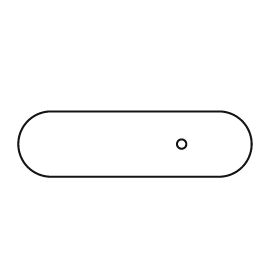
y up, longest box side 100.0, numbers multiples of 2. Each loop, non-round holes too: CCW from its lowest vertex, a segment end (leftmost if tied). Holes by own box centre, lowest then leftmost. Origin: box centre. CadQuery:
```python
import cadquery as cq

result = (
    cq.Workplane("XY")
    .moveTo(-36.0, -14.0)
    .lineTo(36.0, -14.0)
    .threePointArc((50.0, 0.0), (36.0, 14.0))
    .lineTo(-36.0, 14.0)
    .threePointArc((-50.0, 0.0), (-36.0, -14.0))
    .close()
    .moveTo(20.0, 0.0)
    .circle(2.0)
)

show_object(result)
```